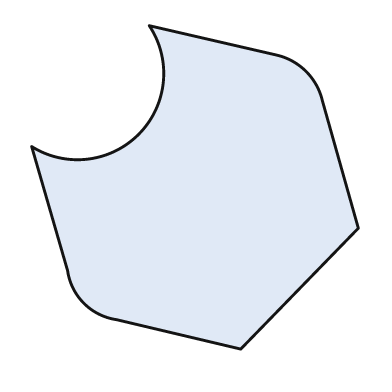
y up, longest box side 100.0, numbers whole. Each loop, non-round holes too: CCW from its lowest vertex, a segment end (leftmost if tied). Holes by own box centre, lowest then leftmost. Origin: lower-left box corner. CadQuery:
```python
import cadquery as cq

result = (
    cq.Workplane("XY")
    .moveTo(64.0, 0.0)
    .lineTo(100.0, 37.0)
    .lineTo(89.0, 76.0)
    .threePointArc((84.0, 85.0), (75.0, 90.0))
    .lineTo(36.0, 99.0)
    .threePointArc((33.0, 66.0), (0.0, 62.0))
    .lineTo(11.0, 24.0)
    .threePointArc((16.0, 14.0), (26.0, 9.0))
    .close()
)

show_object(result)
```